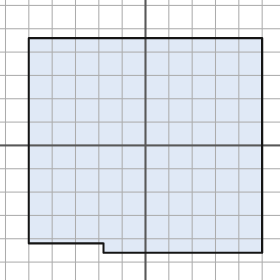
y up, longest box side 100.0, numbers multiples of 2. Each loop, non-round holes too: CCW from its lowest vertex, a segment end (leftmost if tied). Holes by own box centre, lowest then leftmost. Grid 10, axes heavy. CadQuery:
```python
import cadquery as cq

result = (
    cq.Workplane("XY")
    .moveTo(-18.0, -46.0)
    .lineTo(50.0, -46.0)
    .lineTo(50.0, 46.0)
    .lineTo(-50.0, 46.0)
    .lineTo(-50.0, -42.0)
    .lineTo(-18.0, -42.0)
    .close()
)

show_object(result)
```